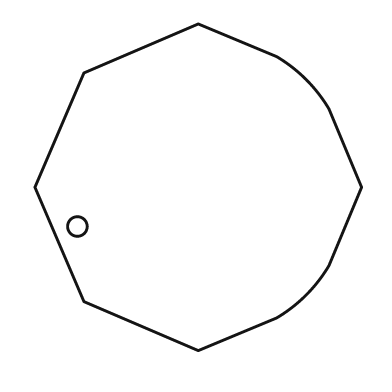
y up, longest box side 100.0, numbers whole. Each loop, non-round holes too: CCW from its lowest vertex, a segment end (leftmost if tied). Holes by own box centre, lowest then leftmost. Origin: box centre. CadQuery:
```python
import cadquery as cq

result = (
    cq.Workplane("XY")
    .moveTo(0.0, -50.0)
    .lineTo(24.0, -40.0)
    .threePointArc((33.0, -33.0), (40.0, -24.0))
    .lineTo(50.0, 0.0)
    .lineTo(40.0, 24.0)
    .threePointArc((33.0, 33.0), (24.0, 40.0))
    .lineTo(0.0, 50.0)
    .lineTo(-35.0, 35.0)
    .lineTo(-50.0, 0.0)
    .lineTo(-35.0, -35.0)
    .close()
    .moveTo(-37.0, -12.0)
    .circle(3.0)
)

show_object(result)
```